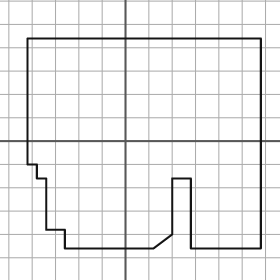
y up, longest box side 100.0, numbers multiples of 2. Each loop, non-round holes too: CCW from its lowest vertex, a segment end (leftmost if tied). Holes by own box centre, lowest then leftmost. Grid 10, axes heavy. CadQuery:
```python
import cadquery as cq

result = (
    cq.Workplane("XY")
    .moveTo(-26.0, -46.0)
    .lineTo(12.0, -46.0)
    .lineTo(20.0, -40.0)
    .lineTo(20.0, -16.0)
    .lineTo(28.0, -16.0)
    .lineTo(28.0, -46.0)
    .lineTo(58.0, -46.0)
    .lineTo(58.0, 44.0)
    .lineTo(-42.0, 44.0)
    .lineTo(-42.0, -10.0)
    .lineTo(-38.0, -10.0)
    .lineTo(-38.0, -16.0)
    .lineTo(-34.0, -16.0)
    .lineTo(-34.0, -38.0)
    .lineTo(-26.0, -38.0)
    .close()
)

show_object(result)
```